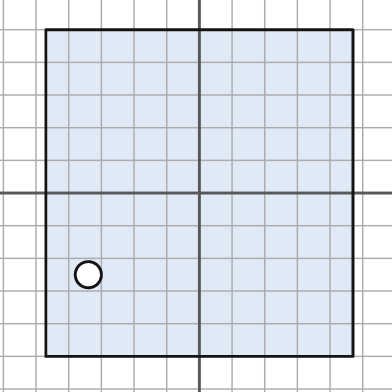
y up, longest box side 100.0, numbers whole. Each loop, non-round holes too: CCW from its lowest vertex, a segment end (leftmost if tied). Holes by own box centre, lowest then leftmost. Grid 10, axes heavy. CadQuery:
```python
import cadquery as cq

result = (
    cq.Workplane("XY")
    .moveTo(-47.0, -50.0)
    .lineTo(47.0, -50.0)
    .lineTo(47.0, 50.0)
    .lineTo(-47.0, 50.0)
    .close()
    .moveTo(-34.0, -25.0)
    .circle(4.0)
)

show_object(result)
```